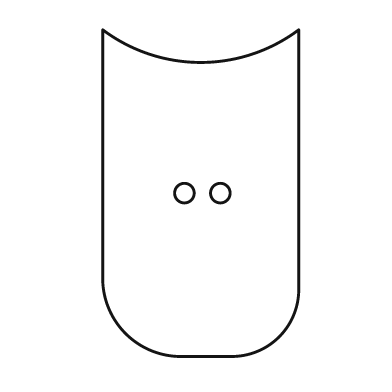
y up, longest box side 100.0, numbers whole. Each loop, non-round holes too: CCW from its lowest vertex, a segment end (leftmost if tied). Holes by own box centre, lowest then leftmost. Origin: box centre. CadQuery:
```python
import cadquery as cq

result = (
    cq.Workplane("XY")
    .moveTo(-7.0, -50.0)
    .lineTo(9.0, -50.0)
    .threePointArc((24.0, -44.0), (30.0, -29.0))
    .lineTo(30.0, 50.0)
    .threePointArc((0.0, 40.0), (-30.0, 50.0))
    .lineTo(-30.0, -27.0)
    .threePointArc((-23.0, -43.0), (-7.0, -50.0))
    .close()
    .moveTo(-5.0, 0.0)
    .circle(3.0)
    .moveTo(6.0, 0.0)
    .circle(3.0)
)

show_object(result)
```